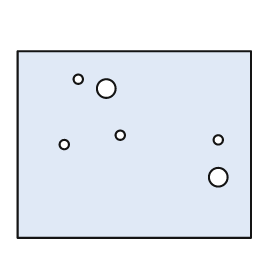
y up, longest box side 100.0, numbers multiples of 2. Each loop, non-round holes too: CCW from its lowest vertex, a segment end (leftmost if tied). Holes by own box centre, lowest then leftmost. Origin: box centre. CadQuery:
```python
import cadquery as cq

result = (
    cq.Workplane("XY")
    .moveTo(-50.0, -40.0)
    .lineTo(50.0, -40.0)
    .lineTo(50.0, 40.0)
    .lineTo(-50.0, 40.0)
    .close()
    .moveTo(36.0, -14.0)
    .circle(4.0)
    .moveTo(-30.0, 0.0)
    .circle(2.0)
    .moveTo(36.0, 2.0)
    .circle(2.0)
    .moveTo(-6.0, 4.0)
    .circle(2.0)
    .moveTo(-12.0, 24.0)
    .circle(4.0)
    .moveTo(-24.0, 28.0)
    .circle(2.0)
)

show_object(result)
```